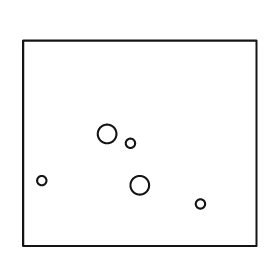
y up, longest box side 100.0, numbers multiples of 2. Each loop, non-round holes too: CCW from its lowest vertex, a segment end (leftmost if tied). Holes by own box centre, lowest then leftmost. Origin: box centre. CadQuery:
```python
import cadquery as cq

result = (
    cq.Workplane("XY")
    .moveTo(-50.0, -44.0)
    .lineTo(50.0, -44.0)
    .lineTo(50.0, 44.0)
    .lineTo(-50.0, 44.0)
    .close()
    .moveTo(26.0, -26.0)
    .circle(2.0)
    .moveTo(0.0, -18.0)
    .circle(4.0)
    .moveTo(-42.0, -16.0)
    .circle(2.0)
    .moveTo(-4.0, 0.0)
    .circle(2.0)
    .moveTo(-14.0, 4.0)
    .circle(4.0)
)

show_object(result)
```